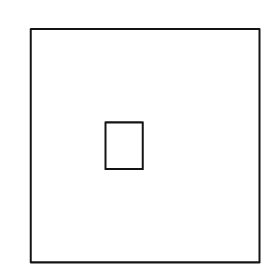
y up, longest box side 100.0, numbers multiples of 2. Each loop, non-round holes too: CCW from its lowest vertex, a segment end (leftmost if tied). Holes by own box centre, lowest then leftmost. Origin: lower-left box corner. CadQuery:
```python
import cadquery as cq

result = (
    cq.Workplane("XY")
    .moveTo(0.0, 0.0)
    .lineTo(98.0, 0.0)
    .lineTo(98.0, 100.0)
    .lineTo(0.0, 100.0)
    .close()
    .moveTo(32.0, 40.0)
    .lineTo(48.0, 40.0)
    .lineTo(48.0, 60.0)
    .lineTo(32.0, 60.0)
    .close()
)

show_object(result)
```